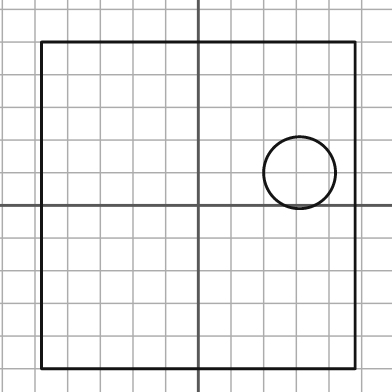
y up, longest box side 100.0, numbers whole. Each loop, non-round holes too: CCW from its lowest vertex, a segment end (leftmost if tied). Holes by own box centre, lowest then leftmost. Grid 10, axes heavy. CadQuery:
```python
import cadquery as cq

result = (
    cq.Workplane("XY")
    .moveTo(-48.0, -50.0)
    .lineTo(48.0, -50.0)
    .lineTo(48.0, 50.0)
    .lineTo(-48.0, 50.0)
    .close()
    .moveTo(31.0, 10.0)
    .circle(11.0)
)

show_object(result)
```